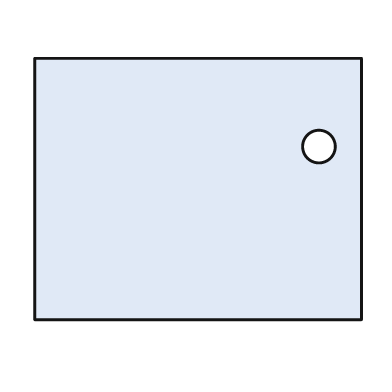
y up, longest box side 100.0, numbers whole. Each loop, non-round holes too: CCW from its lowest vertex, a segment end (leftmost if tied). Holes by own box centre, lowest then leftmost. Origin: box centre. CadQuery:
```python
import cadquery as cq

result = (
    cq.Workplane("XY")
    .moveTo(-50.0, -40.0)
    .lineTo(50.0, -40.0)
    .lineTo(50.0, 40.0)
    .lineTo(-50.0, 40.0)
    .close()
    .moveTo(37.0, 13.0)
    .circle(5.0)
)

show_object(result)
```